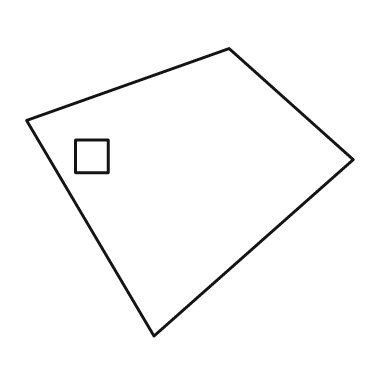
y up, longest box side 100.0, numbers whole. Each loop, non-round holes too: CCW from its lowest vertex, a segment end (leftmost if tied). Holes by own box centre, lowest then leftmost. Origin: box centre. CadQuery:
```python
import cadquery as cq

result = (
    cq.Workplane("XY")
    .moveTo(-11.0, -44.0)
    .lineTo(50.0, 10.0)
    .lineTo(12.0, 44.0)
    .lineTo(-50.0, 22.0)
    .close()
    .moveTo(-35.0, 6.0)
    .lineTo(-25.0, 6.0)
    .lineTo(-25.0, 16.0)
    .lineTo(-35.0, 16.0)
    .close()
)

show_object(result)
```